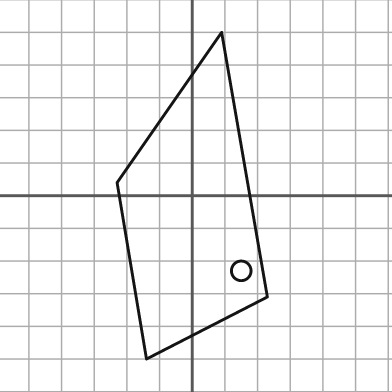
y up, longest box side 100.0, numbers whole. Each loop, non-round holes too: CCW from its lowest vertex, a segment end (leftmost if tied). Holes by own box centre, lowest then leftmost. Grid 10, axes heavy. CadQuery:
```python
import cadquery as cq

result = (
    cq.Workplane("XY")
    .moveTo(-14.0, -50.0)
    .lineTo(23.0, -31.0)
    .lineTo(9.0, 50.0)
    .lineTo(-23.0, 4.0)
    .close()
    .moveTo(15.0, -23.0)
    .circle(3.0)
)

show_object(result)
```